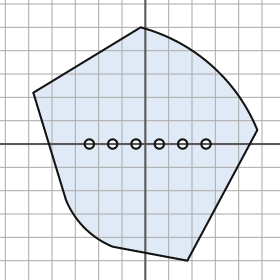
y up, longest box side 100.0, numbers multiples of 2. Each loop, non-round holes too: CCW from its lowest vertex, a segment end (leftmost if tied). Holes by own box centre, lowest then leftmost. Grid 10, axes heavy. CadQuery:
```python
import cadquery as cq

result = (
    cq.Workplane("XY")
    .moveTo(18.0, -50.0)
    .lineTo(48.0, 6.0)
    .threePointArc((28.0, 34.0), (-2.0, 50.0))
    .lineTo(-48.0, 22.0)
    .lineTo(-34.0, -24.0)
    .threePointArc((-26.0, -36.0), (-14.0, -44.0))
    .close()
    .moveTo(-24.0, 0.0)
    .circle(2.0)
    .moveTo(-14.0, 0.0)
    .circle(2.0)
    .moveTo(-4.0, 0.0)
    .circle(2.0)
    .moveTo(6.0, 0.0)
    .circle(2.0)
    .moveTo(16.0, 0.0)
    .circle(2.0)
    .moveTo(26.0, 0.0)
    .circle(2.0)
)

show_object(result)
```